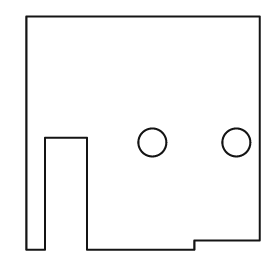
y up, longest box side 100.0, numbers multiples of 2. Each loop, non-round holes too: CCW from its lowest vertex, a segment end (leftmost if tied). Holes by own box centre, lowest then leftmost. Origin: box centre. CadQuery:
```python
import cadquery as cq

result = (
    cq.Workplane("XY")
    .moveTo(-50.0, -50.0)
    .lineTo(-42.0, -50.0)
    .lineTo(-42.0, -2.0)
    .lineTo(-24.0, -2.0)
    .lineTo(-24.0, -50.0)
    .lineTo(22.0, -50.0)
    .lineTo(22.0, -46.0)
    .lineTo(50.0, -46.0)
    .lineTo(50.0, 50.0)
    .lineTo(-50.0, 50.0)
    .close()
    .moveTo(4.0, -4.0)
    .circle(6.0)
    .moveTo(40.0, -4.0)
    .circle(6.0)
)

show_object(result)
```